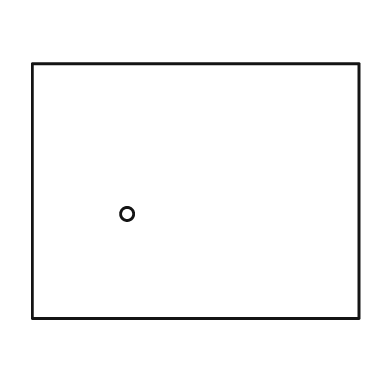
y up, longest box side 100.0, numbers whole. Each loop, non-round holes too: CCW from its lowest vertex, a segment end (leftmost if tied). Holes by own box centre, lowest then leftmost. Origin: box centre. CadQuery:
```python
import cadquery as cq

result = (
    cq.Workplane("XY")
    .moveTo(-50.0, -39.0)
    .lineTo(50.0, -39.0)
    .lineTo(50.0, 39.0)
    .lineTo(-50.0, 39.0)
    .close()
    .moveTo(-21.0, -7.0)
    .circle(2.0)
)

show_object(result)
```